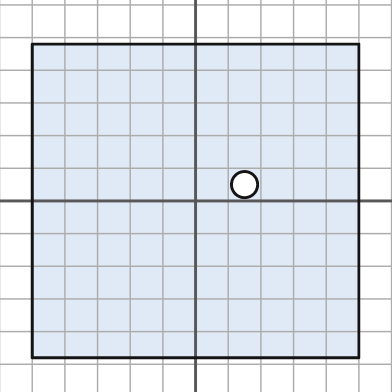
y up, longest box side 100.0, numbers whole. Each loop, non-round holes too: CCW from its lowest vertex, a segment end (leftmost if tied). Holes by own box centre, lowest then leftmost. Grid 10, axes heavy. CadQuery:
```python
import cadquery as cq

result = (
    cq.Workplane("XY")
    .moveTo(-50.0, -48.0)
    .lineTo(50.0, -48.0)
    .lineTo(50.0, 48.0)
    .lineTo(-50.0, 48.0)
    .close()
    .moveTo(15.0, 5.0)
    .circle(4.0)
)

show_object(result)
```